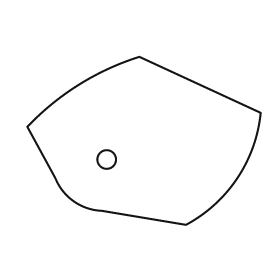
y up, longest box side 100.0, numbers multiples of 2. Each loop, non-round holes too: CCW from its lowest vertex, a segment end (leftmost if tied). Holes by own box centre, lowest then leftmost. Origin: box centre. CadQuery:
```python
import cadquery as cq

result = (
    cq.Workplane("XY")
    .moveTo(18.0, -36.0)
    .threePointArc((40.0, -16.0), (50.0, 12.0))
    .lineTo(-2.0, 36.0)
    .threePointArc((-28.0, 24.0), (-50.0, 6.0))
    .lineTo(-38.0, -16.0)
    .threePointArc((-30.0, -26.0), (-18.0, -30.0))
    .close()
    .moveTo(-16.0, -8.0)
    .circle(4.0)
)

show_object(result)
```